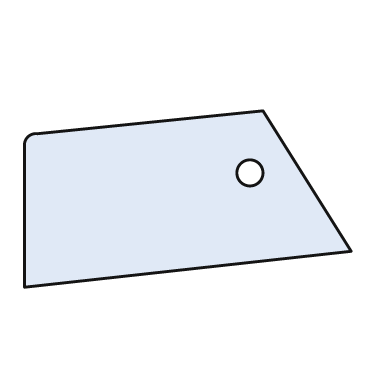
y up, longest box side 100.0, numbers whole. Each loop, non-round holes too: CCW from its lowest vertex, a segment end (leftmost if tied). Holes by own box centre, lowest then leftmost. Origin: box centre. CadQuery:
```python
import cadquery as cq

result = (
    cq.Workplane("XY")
    .moveTo(-50.0, -27.0)
    .lineTo(50.0, -16.0)
    .lineTo(23.0, 27.0)
    .lineTo(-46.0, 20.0)
    .threePointArc((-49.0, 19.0), (-50.0, 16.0))
    .close()
    .moveTo(19.0, 8.0)
    .circle(4.0)
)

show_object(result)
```